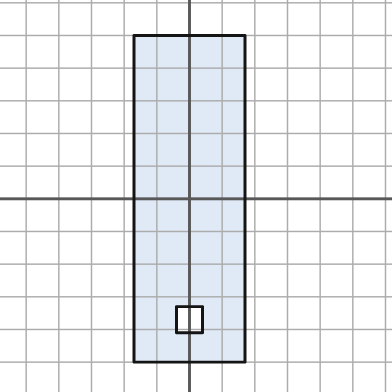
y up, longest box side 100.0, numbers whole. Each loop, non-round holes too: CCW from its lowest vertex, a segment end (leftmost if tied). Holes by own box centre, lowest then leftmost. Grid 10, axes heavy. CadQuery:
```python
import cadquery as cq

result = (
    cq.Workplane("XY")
    .moveTo(-17.0, -50.0)
    .lineTo(17.0, -50.0)
    .lineTo(17.0, 50.0)
    .lineTo(-17.0, 50.0)
    .close()
    .moveTo(-4.0, -41.0)
    .lineTo(4.0, -41.0)
    .lineTo(4.0, -33.0)
    .lineTo(-4.0, -33.0)
    .close()
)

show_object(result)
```